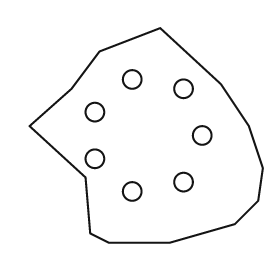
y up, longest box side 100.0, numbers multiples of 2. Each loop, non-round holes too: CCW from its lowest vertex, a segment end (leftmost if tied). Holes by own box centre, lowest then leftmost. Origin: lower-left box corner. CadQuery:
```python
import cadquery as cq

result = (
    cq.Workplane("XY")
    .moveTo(34.0, 0.0)
    .lineTo(60.0, 0.0)
    .lineTo(88.0, 8.0)
    .lineTo(98.0, 18.0)
    .lineTo(100.0, 32.0)
    .lineTo(94.0, 50.0)
    .lineTo(82.0, 68.0)
    .lineTo(56.0, 92.0)
    .lineTo(30.0, 82.0)
    .lineTo(18.0, 66.0)
    .lineTo(0.0, 50.0)
    .lineTo(24.0, 28.0)
    .lineTo(26.0, 4.0)
    .close()
    .moveTo(44.0, 22.0)
    .circle(4.0)
    .moveTo(66.0, 26.0)
    .circle(4.0)
    .moveTo(28.0, 36.0)
    .circle(4.0)
    .moveTo(74.0, 46.0)
    .circle(4.0)
    .moveTo(28.0, 56.0)
    .circle(4.0)
    .moveTo(66.0, 66.0)
    .circle(4.0)
    .moveTo(44.0, 70.0)
    .circle(4.0)
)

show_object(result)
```